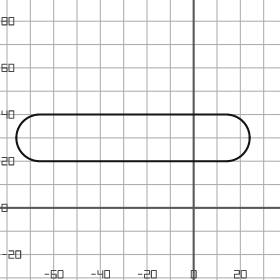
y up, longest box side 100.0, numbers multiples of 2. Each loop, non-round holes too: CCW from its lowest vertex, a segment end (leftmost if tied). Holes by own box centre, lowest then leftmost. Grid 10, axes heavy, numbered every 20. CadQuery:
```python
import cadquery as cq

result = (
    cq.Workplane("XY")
    .moveTo(-66.0, 20.0)
    .lineTo(14.0, 20.0)
    .threePointArc((24.0, 30.0), (14.0, 40.0))
    .lineTo(-66.0, 40.0)
    .threePointArc((-76.0, 30.0), (-66.0, 20.0))
    .close()
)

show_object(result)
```